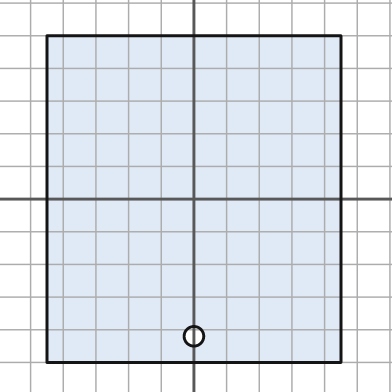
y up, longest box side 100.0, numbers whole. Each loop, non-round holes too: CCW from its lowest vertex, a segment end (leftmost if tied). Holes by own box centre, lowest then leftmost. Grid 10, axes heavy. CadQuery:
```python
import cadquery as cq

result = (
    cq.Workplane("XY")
    .moveTo(-45.0, -50.0)
    .lineTo(45.0, -50.0)
    .lineTo(45.0, 50.0)
    .lineTo(-45.0, 50.0)
    .close()
    .moveTo(0.0, -42.0)
    .circle(3.0)
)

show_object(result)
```